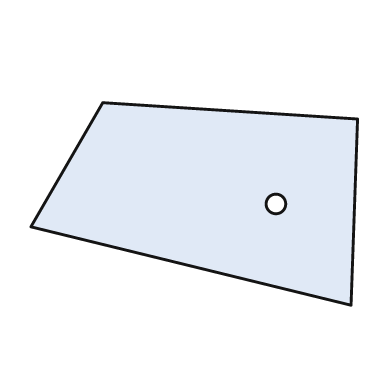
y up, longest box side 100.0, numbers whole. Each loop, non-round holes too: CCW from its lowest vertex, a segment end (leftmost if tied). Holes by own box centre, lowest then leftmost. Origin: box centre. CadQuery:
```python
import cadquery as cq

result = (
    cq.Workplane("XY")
    .moveTo(48.0, -31.0)
    .lineTo(50.0, 26.0)
    .lineTo(-28.0, 31.0)
    .lineTo(-50.0, -7.0)
    .close()
    .moveTo(25.0, 0.0)
    .circle(3.0)
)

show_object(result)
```